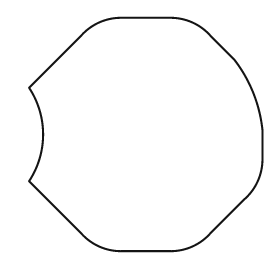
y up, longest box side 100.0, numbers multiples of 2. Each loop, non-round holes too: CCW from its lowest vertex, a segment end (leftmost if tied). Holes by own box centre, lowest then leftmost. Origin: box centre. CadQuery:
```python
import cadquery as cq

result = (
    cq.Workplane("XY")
    .moveTo(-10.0, -50.0)
    .lineTo(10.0, -50.0)
    .threePointArc((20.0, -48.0), (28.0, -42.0))
    .lineTo(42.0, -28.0)
    .threePointArc((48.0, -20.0), (50.0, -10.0))
    .lineTo(50.0, 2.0)
    .threePointArc((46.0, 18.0), (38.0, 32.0))
    .lineTo(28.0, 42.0)
    .threePointArc((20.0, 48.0), (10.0, 50.0))
    .lineTo(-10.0, 50.0)
    .threePointArc((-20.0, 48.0), (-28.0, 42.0))
    .lineTo(-50.0, 20.0)
    .threePointArc((-44.0, 0.0), (-50.0, -20.0))
    .lineTo(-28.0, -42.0)
    .threePointArc((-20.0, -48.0), (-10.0, -50.0))
    .close()
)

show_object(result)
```